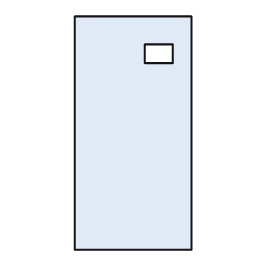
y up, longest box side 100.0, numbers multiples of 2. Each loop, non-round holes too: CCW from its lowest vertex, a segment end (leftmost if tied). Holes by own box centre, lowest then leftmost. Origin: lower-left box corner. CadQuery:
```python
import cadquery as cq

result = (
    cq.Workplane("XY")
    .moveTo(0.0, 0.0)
    .lineTo(50.0, 0.0)
    .lineTo(50.0, 100.0)
    .lineTo(0.0, 100.0)
    .close()
    .moveTo(30.0, 80.0)
    .lineTo(42.0, 80.0)
    .lineTo(42.0, 88.0)
    .lineTo(30.0, 88.0)
    .close()
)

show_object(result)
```